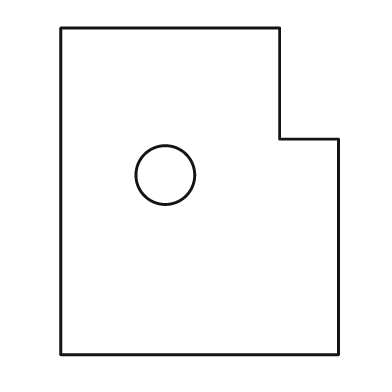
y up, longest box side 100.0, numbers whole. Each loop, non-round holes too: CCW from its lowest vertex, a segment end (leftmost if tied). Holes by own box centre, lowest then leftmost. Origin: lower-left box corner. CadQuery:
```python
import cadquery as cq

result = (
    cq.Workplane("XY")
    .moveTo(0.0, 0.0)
    .lineTo(85.0, 0.0)
    .lineTo(85.0, 66.0)
    .lineTo(67.0, 66.0)
    .lineTo(67.0, 100.0)
    .lineTo(0.0, 100.0)
    .close()
    .moveTo(32.0, 55.0)
    .circle(9.0)
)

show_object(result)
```